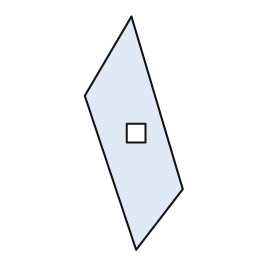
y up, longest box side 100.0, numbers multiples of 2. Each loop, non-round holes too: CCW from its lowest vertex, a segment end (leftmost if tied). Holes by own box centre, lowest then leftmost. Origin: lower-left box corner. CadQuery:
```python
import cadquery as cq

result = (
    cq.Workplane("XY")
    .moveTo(22.0, 0.0)
    .lineTo(42.0, 26.0)
    .lineTo(20.0, 100.0)
    .lineTo(0.0, 66.0)
    .close()
    .moveTo(18.0, 46.0)
    .lineTo(26.0, 46.0)
    .lineTo(26.0, 54.0)
    .lineTo(18.0, 54.0)
    .close()
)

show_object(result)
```